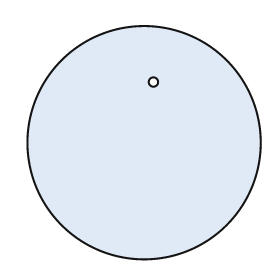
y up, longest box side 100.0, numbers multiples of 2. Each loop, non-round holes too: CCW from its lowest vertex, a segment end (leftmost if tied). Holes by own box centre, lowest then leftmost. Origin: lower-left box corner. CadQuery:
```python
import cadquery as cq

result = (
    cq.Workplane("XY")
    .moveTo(50.0, 50.0)
    .circle(50.0)
    .moveTo(54.0, 76.0)
    .circle(2.0)
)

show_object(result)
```